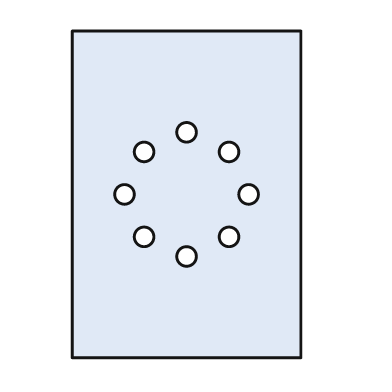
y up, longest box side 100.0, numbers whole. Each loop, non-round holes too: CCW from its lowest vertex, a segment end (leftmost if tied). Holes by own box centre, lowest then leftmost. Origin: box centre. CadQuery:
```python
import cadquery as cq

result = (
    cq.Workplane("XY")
    .moveTo(-35.0, -50.0)
    .lineTo(35.0, -50.0)
    .lineTo(35.0, 50.0)
    .lineTo(-35.0, 50.0)
    .close()
    .moveTo(0.0, -19.0)
    .circle(3.0)
    .moveTo(-13.0, -13.0)
    .circle(3.0)
    .moveTo(13.0, -13.0)
    .circle(3.0)
    .moveTo(-19.0, 0.0)
    .circle(3.0)
    .moveTo(19.0, 0.0)
    .circle(3.0)
    .moveTo(-13.0, 13.0)
    .circle(3.0)
    .moveTo(13.0, 13.0)
    .circle(3.0)
    .moveTo(0.0, 19.0)
    .circle(3.0)
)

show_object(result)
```